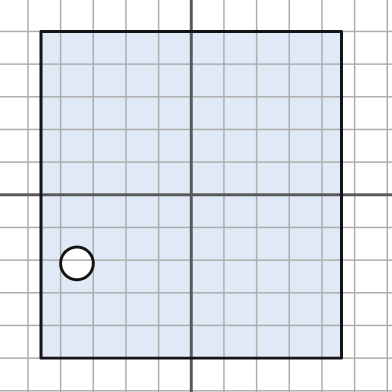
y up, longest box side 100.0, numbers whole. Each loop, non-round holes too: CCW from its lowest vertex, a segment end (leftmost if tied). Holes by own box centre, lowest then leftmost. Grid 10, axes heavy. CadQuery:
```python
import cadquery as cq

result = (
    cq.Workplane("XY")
    .moveTo(-46.0, -50.0)
    .lineTo(46.0, -50.0)
    .lineTo(46.0, 50.0)
    .lineTo(-46.0, 50.0)
    .close()
    .moveTo(-35.0, -21.0)
    .circle(5.0)
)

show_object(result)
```